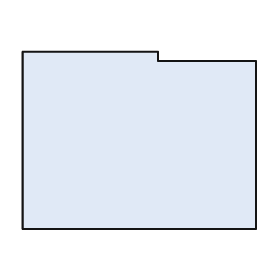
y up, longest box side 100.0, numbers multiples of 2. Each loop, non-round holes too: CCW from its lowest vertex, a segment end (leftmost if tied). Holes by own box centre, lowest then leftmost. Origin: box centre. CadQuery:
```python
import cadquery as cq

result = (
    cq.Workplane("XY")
    .moveTo(-50.0, -38.0)
    .lineTo(50.0, -38.0)
    .lineTo(50.0, 34.0)
    .lineTo(8.0, 34.0)
    .lineTo(8.0, 38.0)
    .lineTo(-50.0, 38.0)
    .close()
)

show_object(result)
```